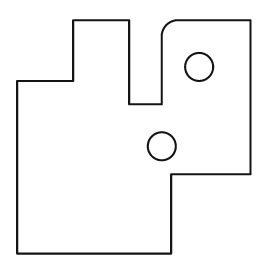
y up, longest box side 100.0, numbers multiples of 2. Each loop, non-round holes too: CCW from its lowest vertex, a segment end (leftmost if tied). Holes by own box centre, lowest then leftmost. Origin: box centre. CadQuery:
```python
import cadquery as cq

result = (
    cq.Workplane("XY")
    .moveTo(-50.0, -50.0)
    .lineTo(16.0, -50.0)
    .lineTo(16.0, -16.0)
    .lineTo(50.0, -16.0)
    .lineTo(50.0, 50.0)
    .lineTo(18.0, 50.0)
    .threePointArc((14.0, 48.0), (12.0, 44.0))
    .lineTo(12.0, 14.0)
    .lineTo(-2.0, 14.0)
    .lineTo(-2.0, 50.0)
    .lineTo(-26.0, 50.0)
    .lineTo(-26.0, 24.0)
    .lineTo(-50.0, 24.0)
    .close()
    .moveTo(12.0, -4.0)
    .circle(6.0)
    .moveTo(28.0, 30.0)
    .circle(6.0)
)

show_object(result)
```